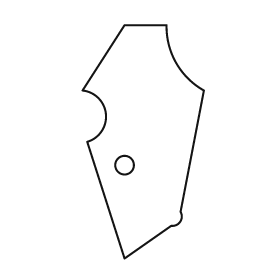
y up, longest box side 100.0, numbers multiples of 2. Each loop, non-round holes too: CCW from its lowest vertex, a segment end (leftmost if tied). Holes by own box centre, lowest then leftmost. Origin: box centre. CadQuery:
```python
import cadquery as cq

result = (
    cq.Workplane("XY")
    .moveTo(-8.0, -50.0)
    .lineTo(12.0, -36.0)
    .threePointArc((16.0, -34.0), (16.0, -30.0))
    .lineTo(26.0, 22.0)
    .threePointArc((14.0, 34.0), (10.0, 50.0))
    .lineTo(-8.0, 50.0)
    .lineTo(-26.0, 22.0)
    .threePointArc((-16.0, 12.0), (-24.0, 0.0))
    .close()
    .moveTo(-8.0, -10.0)
    .circle(4.0)
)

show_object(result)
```